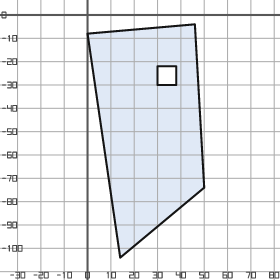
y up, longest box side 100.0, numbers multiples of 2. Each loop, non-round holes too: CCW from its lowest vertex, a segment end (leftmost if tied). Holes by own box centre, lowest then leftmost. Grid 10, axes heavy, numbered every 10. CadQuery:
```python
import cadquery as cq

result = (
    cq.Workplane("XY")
    .moveTo(14.0, -104.0)
    .lineTo(50.0, -74.0)
    .lineTo(46.0, -4.0)
    .lineTo(0.0, -8.0)
    .close()
    .moveTo(30.0, -30.0)
    .lineTo(38.0, -30.0)
    .lineTo(38.0, -22.0)
    .lineTo(30.0, -22.0)
    .close()
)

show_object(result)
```